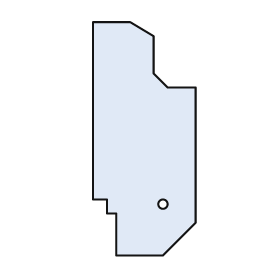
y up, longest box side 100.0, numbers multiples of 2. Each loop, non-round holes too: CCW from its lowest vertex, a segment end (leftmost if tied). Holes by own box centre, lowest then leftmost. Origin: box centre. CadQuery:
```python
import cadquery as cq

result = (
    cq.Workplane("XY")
    .moveTo(-12.0, -50.0)
    .lineTo(8.0, -50.0)
    .lineTo(22.0, -36.0)
    .lineTo(22.0, 22.0)
    .lineTo(10.0, 22.0)
    .lineTo(4.0, 28.0)
    .lineTo(4.0, 44.0)
    .lineTo(-6.0, 50.0)
    .lineTo(-22.0, 50.0)
    .lineTo(-22.0, -26.0)
    .lineTo(-16.0, -26.0)
    .lineTo(-16.0, -32.0)
    .lineTo(-12.0, -32.0)
    .close()
    .moveTo(8.0, -28.0)
    .circle(2.0)
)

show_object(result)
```